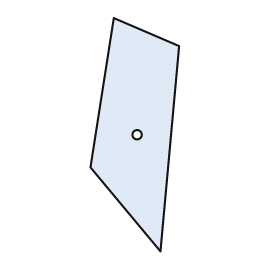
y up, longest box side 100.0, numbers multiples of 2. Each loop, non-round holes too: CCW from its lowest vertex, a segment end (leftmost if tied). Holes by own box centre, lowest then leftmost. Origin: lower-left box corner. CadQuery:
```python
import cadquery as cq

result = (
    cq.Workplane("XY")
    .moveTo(30.0, 0.0)
    .lineTo(38.0, 88.0)
    .lineTo(10.0, 100.0)
    .lineTo(0.0, 36.0)
    .close()
    .moveTo(20.0, 50.0)
    .circle(2.0)
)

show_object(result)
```